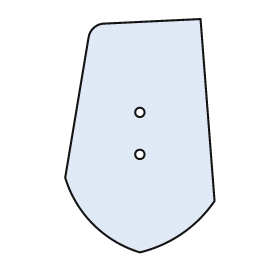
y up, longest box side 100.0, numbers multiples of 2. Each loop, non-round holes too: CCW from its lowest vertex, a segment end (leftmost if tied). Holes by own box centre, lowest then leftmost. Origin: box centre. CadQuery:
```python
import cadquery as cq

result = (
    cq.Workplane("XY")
    .moveTo(0.0, -50.0)
    .threePointArc((18.0, -42.0), (32.0, -28.0))
    .lineTo(26.0, 50.0)
    .lineTo(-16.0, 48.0)
    .threePointArc((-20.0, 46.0), (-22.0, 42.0))
    .lineTo(-32.0, -18.0)
    .threePointArc((-20.0, -38.0), (0.0, -50.0))
    .close()
    .moveTo(0.0, -8.0)
    .circle(2.0)
    .moveTo(0.0, 10.0)
    .circle(2.0)
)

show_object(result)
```